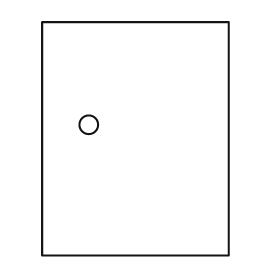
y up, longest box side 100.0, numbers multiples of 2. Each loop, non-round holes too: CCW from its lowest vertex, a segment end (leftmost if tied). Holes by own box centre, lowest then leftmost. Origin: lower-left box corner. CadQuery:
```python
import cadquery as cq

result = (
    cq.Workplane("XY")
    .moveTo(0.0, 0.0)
    .lineTo(80.0, 0.0)
    .lineTo(80.0, 100.0)
    .lineTo(0.0, 100.0)
    .close()
    .moveTo(20.0, 56.0)
    .circle(4.0)
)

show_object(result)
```